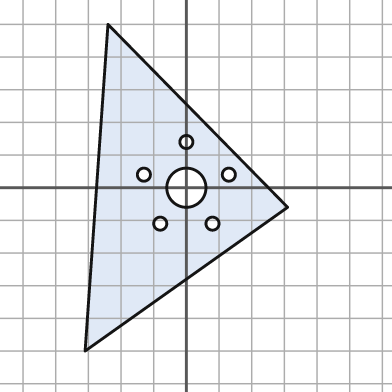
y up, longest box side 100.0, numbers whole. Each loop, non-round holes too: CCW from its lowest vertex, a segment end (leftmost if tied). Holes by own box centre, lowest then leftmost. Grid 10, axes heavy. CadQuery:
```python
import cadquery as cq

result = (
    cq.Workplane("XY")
    .moveTo(-31.0, -50.0)
    .lineTo(31.0, -6.0)
    .lineTo(-24.0, 50.0)
    .close()
    .moveTo(-8.0, -11.0)
    .circle(2.0)
    .moveTo(8.0, -11.0)
    .circle(2.0)
    .moveTo(0.0, 0.0)
    .circle(6.0)
    .moveTo(-13.0, 4.0)
    .circle(2.0)
    .moveTo(13.0, 4.0)
    .circle(2.0)
    .moveTo(0.0, 14.0)
    .circle(2.0)
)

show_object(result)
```